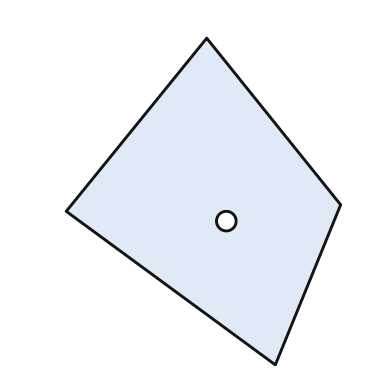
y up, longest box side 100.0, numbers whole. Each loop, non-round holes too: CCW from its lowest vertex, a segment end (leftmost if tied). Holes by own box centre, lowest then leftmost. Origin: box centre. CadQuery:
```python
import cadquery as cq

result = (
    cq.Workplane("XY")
    .moveTo(22.0, -50.0)
    .lineTo(42.0, -1.0)
    .lineTo(1.0, 50.0)
    .lineTo(-42.0, -3.0)
    .close()
    .moveTo(7.0, -6.0)
    .circle(3.0)
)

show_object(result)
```